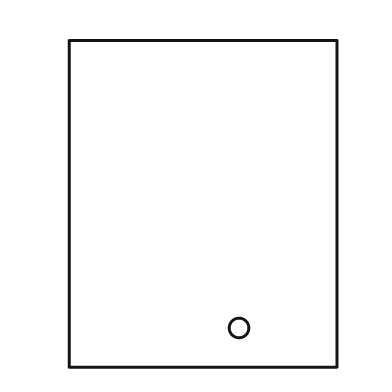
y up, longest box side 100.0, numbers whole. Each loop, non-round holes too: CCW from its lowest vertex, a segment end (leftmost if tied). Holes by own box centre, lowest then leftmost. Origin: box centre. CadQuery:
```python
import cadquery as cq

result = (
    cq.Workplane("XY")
    .moveTo(-41.0, -50.0)
    .lineTo(41.0, -50.0)
    .lineTo(41.0, 50.0)
    .lineTo(-41.0, 50.0)
    .close()
    .moveTo(11.0, -38.0)
    .circle(3.0)
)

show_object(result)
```